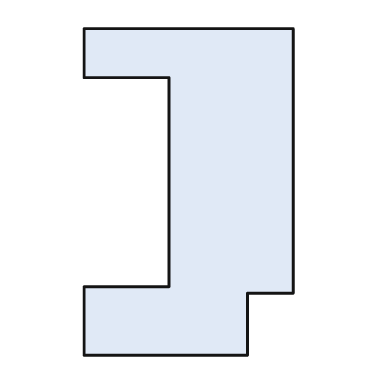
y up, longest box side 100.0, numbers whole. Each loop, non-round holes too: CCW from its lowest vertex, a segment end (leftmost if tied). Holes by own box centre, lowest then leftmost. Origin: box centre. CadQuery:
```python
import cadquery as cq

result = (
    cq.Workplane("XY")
    .moveTo(-32.0, -50.0)
    .lineTo(18.0, -50.0)
    .lineTo(18.0, -31.0)
    .lineTo(32.0, -31.0)
    .lineTo(32.0, 50.0)
    .lineTo(-32.0, 50.0)
    .lineTo(-32.0, 35.0)
    .lineTo(-6.0, 35.0)
    .lineTo(-6.0, -29.0)
    .lineTo(-32.0, -29.0)
    .close()
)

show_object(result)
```